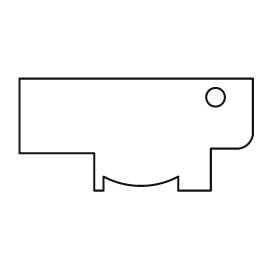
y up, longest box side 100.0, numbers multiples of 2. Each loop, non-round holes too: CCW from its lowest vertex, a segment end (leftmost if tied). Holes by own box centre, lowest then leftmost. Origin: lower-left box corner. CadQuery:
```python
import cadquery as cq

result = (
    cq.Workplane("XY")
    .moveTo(32.0, 0.0)
    .lineTo(36.0, 0.0)
    .lineTo(36.0, 6.0)
    .threePointArc((52.0, 2.0), (68.0, 6.0))
    .lineTo(68.0, 0.0)
    .lineTo(82.0, 0.0)
    .lineTo(82.0, 18.0)
    .lineTo(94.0, 18.0)
    .threePointArc((98.0, 20.0), (100.0, 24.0))
    .lineTo(100.0, 48.0)
    .lineTo(0.0, 48.0)
    .lineTo(0.0, 16.0)
    .lineTo(32.0, 16.0)
    .close()
    .moveTo(84.0, 40.0)
    .circle(4.0)
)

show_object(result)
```